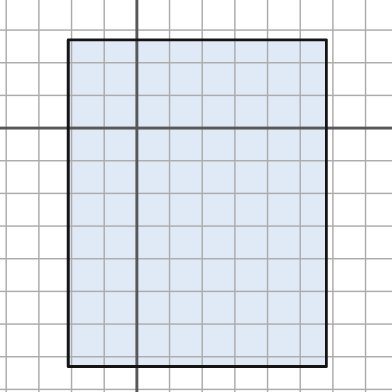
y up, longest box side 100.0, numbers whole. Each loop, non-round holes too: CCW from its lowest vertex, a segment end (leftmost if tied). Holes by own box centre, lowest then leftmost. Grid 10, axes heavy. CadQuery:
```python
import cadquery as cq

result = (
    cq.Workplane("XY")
    .moveTo(-21.0, -73.0)
    .lineTo(58.0, -73.0)
    .lineTo(58.0, 27.0)
    .lineTo(-21.0, 27.0)
    .close()
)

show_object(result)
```